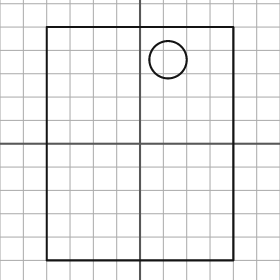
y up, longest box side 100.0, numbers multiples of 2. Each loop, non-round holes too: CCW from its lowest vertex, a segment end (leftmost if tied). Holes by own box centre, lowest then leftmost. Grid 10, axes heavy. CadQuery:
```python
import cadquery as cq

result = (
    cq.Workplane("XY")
    .moveTo(-40.0, -50.0)
    .lineTo(40.0, -50.0)
    .lineTo(40.0, 50.0)
    .lineTo(-40.0, 50.0)
    .close()
    .moveTo(12.0, 36.0)
    .circle(8.0)
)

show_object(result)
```